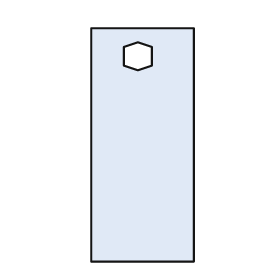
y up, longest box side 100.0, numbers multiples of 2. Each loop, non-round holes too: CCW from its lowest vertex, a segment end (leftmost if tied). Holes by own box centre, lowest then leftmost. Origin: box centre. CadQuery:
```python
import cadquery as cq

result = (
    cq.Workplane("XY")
    .moveTo(-22.0, -50.0)
    .lineTo(22.0, -50.0)
    .lineTo(22.0, 50.0)
    .lineTo(-22.0, 50.0)
    .close()
    .moveTo(-2.0, 32.0)
    .lineTo(4.0, 34.0)
    .lineTo(4.0, 42.0)
    .lineTo(-2.0, 44.0)
    .lineTo(-8.0, 42.0)
    .lineTo(-8.0, 34.0)
    .close()
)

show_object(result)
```